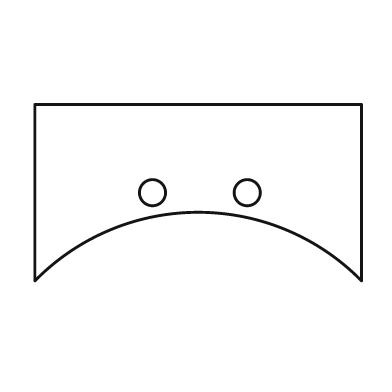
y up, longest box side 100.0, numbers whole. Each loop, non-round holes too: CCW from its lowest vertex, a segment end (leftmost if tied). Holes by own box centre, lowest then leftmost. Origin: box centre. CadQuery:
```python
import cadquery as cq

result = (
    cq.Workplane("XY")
    .moveTo(-50.0, -27.0)
    .threePointArc((0.0, -6.0), (50.0, -27.0))
    .lineTo(50.0, 27.0)
    .lineTo(-50.0, 27.0)
    .close()
    .moveTo(-14.0, 0.0)
    .circle(4.0)
    .moveTo(15.0, 0.0)
    .circle(4.0)
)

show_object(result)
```